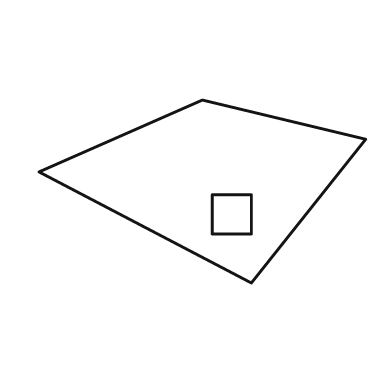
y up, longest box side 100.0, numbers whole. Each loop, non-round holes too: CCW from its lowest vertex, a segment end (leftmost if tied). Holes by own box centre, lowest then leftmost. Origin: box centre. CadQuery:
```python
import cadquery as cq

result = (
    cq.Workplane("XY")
    .moveTo(15.0, -28.0)
    .lineTo(50.0, 16.0)
    .lineTo(0.0, 28.0)
    .lineTo(-50.0, 6.0)
    .close()
    .moveTo(3.0, -13.0)
    .lineTo(15.0, -13.0)
    .lineTo(15.0, -1.0)
    .lineTo(3.0, -1.0)
    .close()
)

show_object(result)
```